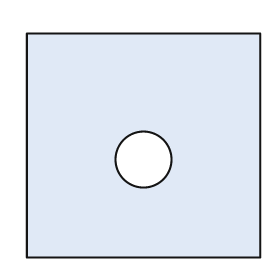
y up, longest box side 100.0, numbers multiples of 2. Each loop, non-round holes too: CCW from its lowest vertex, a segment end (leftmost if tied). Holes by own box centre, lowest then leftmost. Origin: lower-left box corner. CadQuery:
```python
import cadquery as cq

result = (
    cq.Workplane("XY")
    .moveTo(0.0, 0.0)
    .lineTo(100.0, 0.0)
    .lineTo(100.0, 96.0)
    .lineTo(0.0, 96.0)
    .close()
    .moveTo(50.0, 42.0)
    .circle(12.0)
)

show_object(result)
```